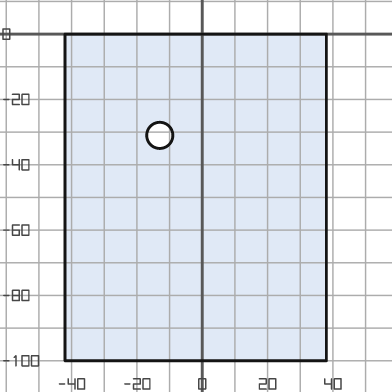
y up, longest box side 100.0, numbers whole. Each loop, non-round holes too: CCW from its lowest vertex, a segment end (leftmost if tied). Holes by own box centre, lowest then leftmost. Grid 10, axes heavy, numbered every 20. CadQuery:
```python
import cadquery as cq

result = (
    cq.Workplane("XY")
    .moveTo(-42.0, -100.0)
    .lineTo(38.0, -100.0)
    .lineTo(38.0, 0.0)
    .lineTo(-42.0, 0.0)
    .close()
    .moveTo(-13.0, -31.0)
    .circle(4.0)
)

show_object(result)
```